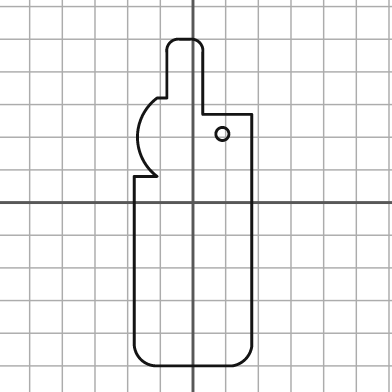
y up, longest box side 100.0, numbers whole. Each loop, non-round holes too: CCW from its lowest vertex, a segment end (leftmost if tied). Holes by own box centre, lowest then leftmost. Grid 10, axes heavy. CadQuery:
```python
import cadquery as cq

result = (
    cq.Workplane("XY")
    .moveTo(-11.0, -50.0)
    .lineTo(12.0, -50.0)
    .threePointArc((16.0, -48.0), (18.0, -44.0))
    .lineTo(18.0, 27.0)
    .lineTo(3.0, 27.0)
    .lineTo(3.0, 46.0)
    .threePointArc((2.0, 49.0), (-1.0, 50.0))
    .lineTo(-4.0, 50.0)
    .threePointArc((-7.0, 49.0), (-8.0, 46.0))
    .lineTo(-8.0, 32.0)
    .lineTo(-11.0, 32.0)
    .threePointArc((-17.0, 20.0), (-11.0, 8.0))
    .lineTo(-18.0, 8.0)
    .lineTo(-18.0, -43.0)
    .threePointArc((-16.0, -48.0), (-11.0, -50.0))
    .close()
    .moveTo(9.0, 21.0)
    .circle(2.0)
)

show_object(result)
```